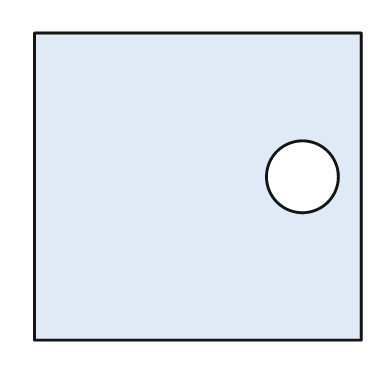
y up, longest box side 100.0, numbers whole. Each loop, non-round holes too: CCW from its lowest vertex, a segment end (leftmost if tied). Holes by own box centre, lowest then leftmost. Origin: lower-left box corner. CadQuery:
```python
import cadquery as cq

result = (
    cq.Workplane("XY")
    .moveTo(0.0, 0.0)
    .lineTo(100.0, 0.0)
    .lineTo(100.0, 94.0)
    .lineTo(0.0, 94.0)
    .close()
    .moveTo(82.0, 50.0)
    .circle(11.0)
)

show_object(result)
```